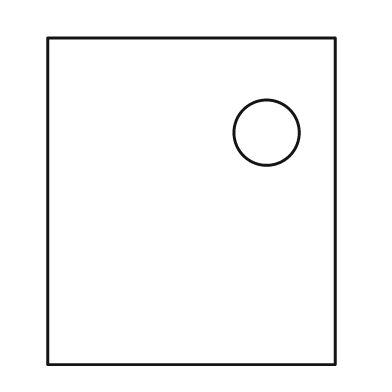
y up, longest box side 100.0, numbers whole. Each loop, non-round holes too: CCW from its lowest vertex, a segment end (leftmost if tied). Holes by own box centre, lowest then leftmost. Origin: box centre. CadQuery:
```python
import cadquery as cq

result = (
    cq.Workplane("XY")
    .moveTo(-44.0, -50.0)
    .lineTo(44.0, -50.0)
    .lineTo(44.0, 50.0)
    .lineTo(-44.0, 50.0)
    .close()
    .moveTo(23.0, 21.0)
    .circle(10.0)
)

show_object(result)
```